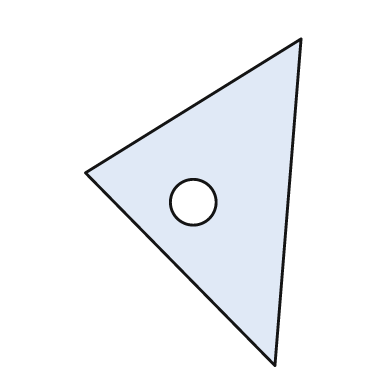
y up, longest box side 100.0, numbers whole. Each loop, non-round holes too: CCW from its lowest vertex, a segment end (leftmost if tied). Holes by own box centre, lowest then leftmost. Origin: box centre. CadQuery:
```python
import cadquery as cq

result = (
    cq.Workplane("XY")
    .moveTo(25.0, -50.0)
    .lineTo(33.0, 50.0)
    .lineTo(-33.0, 9.0)
    .close()
    .moveTo(0.0, 0.0)
    .circle(7.0)
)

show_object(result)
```